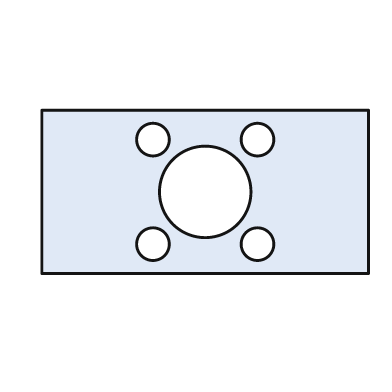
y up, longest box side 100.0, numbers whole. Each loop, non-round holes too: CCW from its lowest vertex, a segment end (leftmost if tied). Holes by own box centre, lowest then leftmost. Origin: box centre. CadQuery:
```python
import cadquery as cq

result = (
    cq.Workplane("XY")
    .moveTo(-50.0, -25.0)
    .lineTo(50.0, -25.0)
    .lineTo(50.0, 25.0)
    .lineTo(-50.0, 25.0)
    .close()
    .moveTo(-16.0, -16.0)
    .circle(5.0)
    .moveTo(16.0, -16.0)
    .circle(5.0)
    .moveTo(0.0, 0.0)
    .circle(14.0)
    .moveTo(-16.0, 16.0)
    .circle(5.0)
    .moveTo(16.0, 16.0)
    .circle(5.0)
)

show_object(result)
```